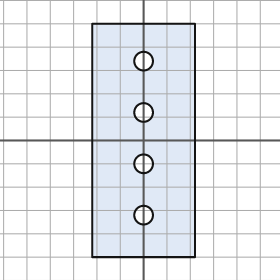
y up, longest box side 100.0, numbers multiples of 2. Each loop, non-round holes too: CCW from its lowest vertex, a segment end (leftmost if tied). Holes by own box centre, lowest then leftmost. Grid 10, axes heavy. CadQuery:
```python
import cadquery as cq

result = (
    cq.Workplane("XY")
    .moveTo(-22.0, -50.0)
    .lineTo(22.0, -50.0)
    .lineTo(22.0, 50.0)
    .lineTo(-22.0, 50.0)
    .close()
    .moveTo(0.0, -32.0)
    .circle(4.0)
    .moveTo(0.0, -10.0)
    .circle(4.0)
    .moveTo(0.0, 12.0)
    .circle(4.0)
    .moveTo(0.0, 34.0)
    .circle(4.0)
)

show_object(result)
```